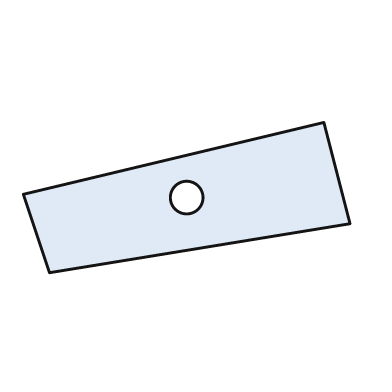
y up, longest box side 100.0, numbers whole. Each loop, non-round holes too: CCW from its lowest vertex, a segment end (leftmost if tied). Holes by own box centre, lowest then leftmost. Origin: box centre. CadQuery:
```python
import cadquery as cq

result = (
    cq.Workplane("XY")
    .moveTo(-42.0, -23.0)
    .lineTo(50.0, -8.0)
    .lineTo(42.0, 23.0)
    .lineTo(-50.0, 1.0)
    .close()
    .moveTo(0.0, 0.0)
    .circle(5.0)
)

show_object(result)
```